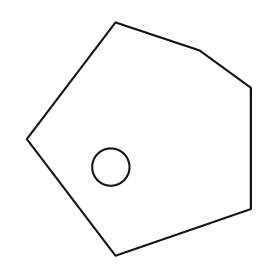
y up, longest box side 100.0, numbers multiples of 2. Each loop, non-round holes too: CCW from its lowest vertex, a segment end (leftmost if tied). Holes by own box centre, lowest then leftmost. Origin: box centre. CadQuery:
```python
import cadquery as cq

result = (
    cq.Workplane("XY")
    .moveTo(-10.0, -50.0)
    .lineTo(48.0, -30.0)
    .lineTo(48.0, 22.0)
    .lineTo(26.0, 38.0)
    .lineTo(-10.0, 50.0)
    .lineTo(-48.0, 0.0)
    .close()
    .moveTo(-12.0, -12.0)
    .circle(8.0)
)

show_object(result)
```